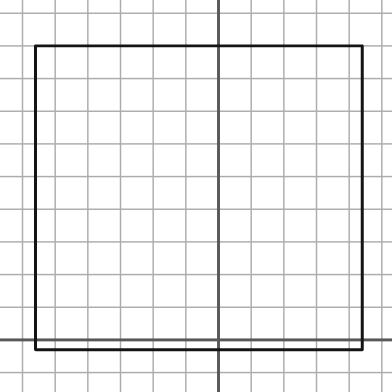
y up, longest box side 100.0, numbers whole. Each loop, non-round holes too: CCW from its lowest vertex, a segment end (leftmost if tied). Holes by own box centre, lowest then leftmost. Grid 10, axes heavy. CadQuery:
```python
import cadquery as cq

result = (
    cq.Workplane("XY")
    .moveTo(-56.0, -3.0)
    .lineTo(44.0, -3.0)
    .lineTo(44.0, 90.0)
    .lineTo(-56.0, 90.0)
    .close()
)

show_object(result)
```